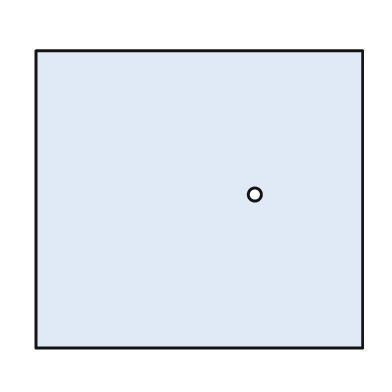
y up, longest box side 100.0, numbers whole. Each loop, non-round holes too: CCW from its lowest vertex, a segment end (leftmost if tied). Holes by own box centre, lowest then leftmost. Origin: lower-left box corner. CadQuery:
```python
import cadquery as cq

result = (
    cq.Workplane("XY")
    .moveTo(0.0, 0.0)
    .lineTo(100.0, 0.0)
    .lineTo(100.0, 91.0)
    .lineTo(0.0, 91.0)
    .close()
    .moveTo(67.0, 47.0)
    .circle(2.0)
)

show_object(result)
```